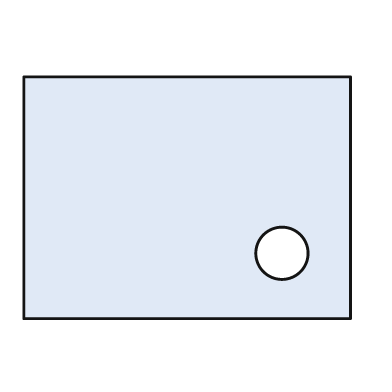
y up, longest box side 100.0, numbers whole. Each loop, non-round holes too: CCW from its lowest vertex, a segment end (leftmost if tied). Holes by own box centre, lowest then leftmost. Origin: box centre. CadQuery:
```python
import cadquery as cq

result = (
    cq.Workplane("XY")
    .moveTo(-50.0, -37.0)
    .lineTo(50.0, -37.0)
    .lineTo(50.0, 37.0)
    .lineTo(-50.0, 37.0)
    .close()
    .moveTo(29.0, -17.0)
    .circle(8.0)
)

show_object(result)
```